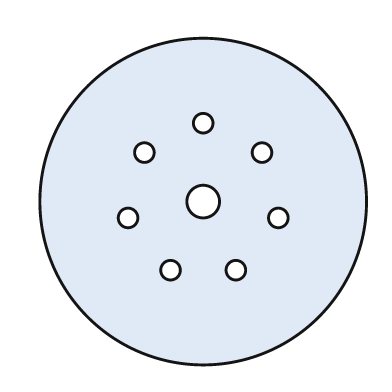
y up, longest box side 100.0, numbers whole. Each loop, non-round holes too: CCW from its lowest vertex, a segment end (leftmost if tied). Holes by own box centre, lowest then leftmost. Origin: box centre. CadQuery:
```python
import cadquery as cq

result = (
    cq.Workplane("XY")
    .moveTo(0.0, 0.0)
    .circle(50.0)
    .moveTo(-10.0, -21.0)
    .circle(3.0)
    .moveTo(10.0, -21.0)
    .circle(3.0)
    .moveTo(-23.0, -5.0)
    .circle(3.0)
    .moveTo(23.0, -5.0)
    .circle(3.0)
    .moveTo(0.0, 0.0)
    .circle(5.0)
    .moveTo(-18.0, 15.0)
    .circle(3.0)
    .moveTo(18.0, 15.0)
    .circle(3.0)
    .moveTo(0.0, 24.0)
    .circle(3.0)
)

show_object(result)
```